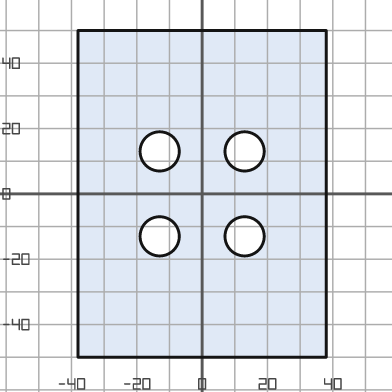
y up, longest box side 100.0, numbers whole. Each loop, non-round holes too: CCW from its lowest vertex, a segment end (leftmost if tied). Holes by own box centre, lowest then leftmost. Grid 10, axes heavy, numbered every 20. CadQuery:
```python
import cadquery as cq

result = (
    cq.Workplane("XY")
    .moveTo(-38.0, -50.0)
    .lineTo(38.0, -50.0)
    .lineTo(38.0, 50.0)
    .lineTo(-38.0, 50.0)
    .close()
    .moveTo(-13.0, -13.0)
    .circle(6.0)
    .moveTo(13.0, -13.0)
    .circle(6.0)
    .moveTo(-13.0, 13.0)
    .circle(6.0)
    .moveTo(13.0, 13.0)
    .circle(6.0)
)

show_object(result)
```